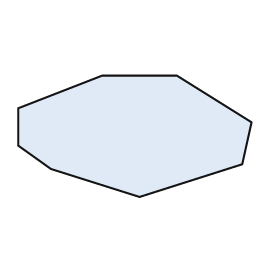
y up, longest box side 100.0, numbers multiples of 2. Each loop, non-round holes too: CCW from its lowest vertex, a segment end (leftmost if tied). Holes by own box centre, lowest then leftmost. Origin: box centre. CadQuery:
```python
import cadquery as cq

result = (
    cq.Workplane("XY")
    .moveTo(2.0, -26.0)
    .lineTo(46.0, -12.0)
    .lineTo(50.0, 6.0)
    .lineTo(18.0, 26.0)
    .lineTo(-14.0, 26.0)
    .lineTo(-50.0, 12.0)
    .lineTo(-50.0, -4.0)
    .lineTo(-36.0, -14.0)
    .close()
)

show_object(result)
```